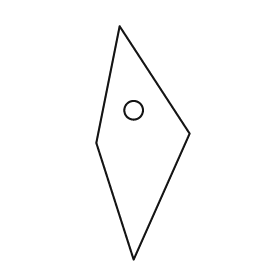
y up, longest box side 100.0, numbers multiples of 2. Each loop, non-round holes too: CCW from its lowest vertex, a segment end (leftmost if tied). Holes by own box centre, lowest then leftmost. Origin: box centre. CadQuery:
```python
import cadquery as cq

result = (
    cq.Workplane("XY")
    .moveTo(-4.0, -50.0)
    .lineTo(20.0, 4.0)
    .lineTo(-10.0, 50.0)
    .lineTo(-20.0, 0.0)
    .close()
    .moveTo(-4.0, 14.0)
    .circle(4.0)
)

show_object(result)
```